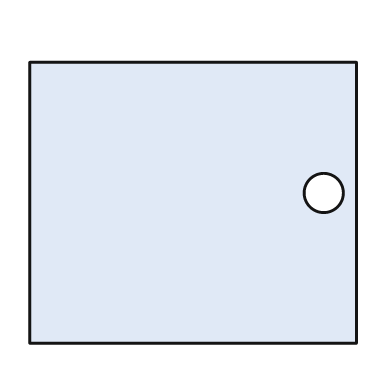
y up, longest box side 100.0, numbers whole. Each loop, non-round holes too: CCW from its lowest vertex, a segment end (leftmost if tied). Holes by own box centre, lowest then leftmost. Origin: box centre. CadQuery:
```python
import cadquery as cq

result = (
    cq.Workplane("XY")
    .moveTo(-50.0, -43.0)
    .lineTo(50.0, -43.0)
    .lineTo(50.0, 43.0)
    .lineTo(-50.0, 43.0)
    .close()
    .moveTo(40.0, 3.0)
    .circle(6.0)
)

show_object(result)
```